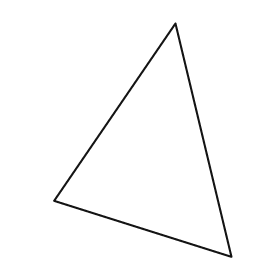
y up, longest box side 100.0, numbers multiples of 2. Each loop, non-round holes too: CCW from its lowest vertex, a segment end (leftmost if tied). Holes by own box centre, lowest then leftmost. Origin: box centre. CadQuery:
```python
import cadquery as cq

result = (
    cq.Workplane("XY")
    .moveTo(38.0, -50.0)
    .lineTo(14.0, 50.0)
    .lineTo(-38.0, -26.0)
    .close()
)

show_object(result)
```